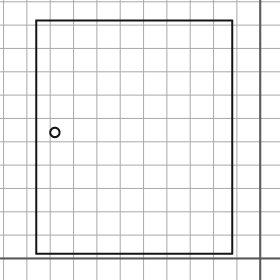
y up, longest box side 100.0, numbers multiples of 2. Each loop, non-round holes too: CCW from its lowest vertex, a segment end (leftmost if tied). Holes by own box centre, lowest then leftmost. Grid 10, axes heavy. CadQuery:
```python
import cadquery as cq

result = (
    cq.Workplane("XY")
    .moveTo(-96.0, 2.0)
    .lineTo(-12.0, 2.0)
    .lineTo(-12.0, 102.0)
    .lineTo(-96.0, 102.0)
    .close()
    .moveTo(-88.0, 54.0)
    .circle(2.0)
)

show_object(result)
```